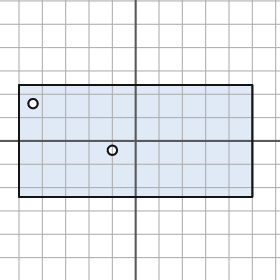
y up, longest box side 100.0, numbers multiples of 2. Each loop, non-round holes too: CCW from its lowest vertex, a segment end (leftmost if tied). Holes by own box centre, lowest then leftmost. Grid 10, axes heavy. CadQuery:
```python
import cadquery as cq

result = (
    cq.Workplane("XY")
    .moveTo(-50.0, -24.0)
    .lineTo(50.0, -24.0)
    .lineTo(50.0, 24.0)
    .lineTo(-50.0, 24.0)
    .close()
    .moveTo(-10.0, -4.0)
    .circle(2.0)
    .moveTo(-44.0, 16.0)
    .circle(2.0)
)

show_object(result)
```